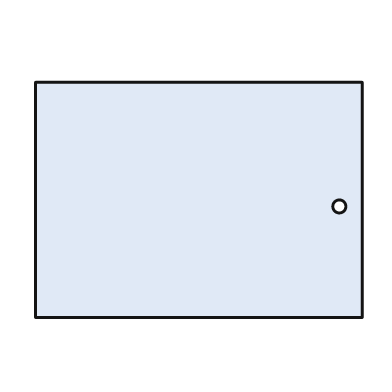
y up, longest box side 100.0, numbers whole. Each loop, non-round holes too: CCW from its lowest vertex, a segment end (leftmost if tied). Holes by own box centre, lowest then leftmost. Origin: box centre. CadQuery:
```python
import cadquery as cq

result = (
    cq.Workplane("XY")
    .moveTo(-50.0, -36.0)
    .lineTo(50.0, -36.0)
    .lineTo(50.0, 36.0)
    .lineTo(-50.0, 36.0)
    .close()
    .moveTo(43.0, -2.0)
    .circle(2.0)
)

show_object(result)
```